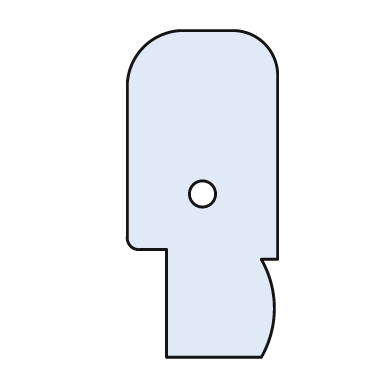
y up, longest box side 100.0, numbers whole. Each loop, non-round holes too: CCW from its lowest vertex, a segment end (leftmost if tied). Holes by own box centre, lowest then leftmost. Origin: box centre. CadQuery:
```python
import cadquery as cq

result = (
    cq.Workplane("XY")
    .moveTo(-11.0, -50.0)
    .lineTo(18.0, -50.0)
    .threePointArc((22.0, -35.0), (18.0, -20.0))
    .lineTo(23.0, -20.0)
    .lineTo(23.0, 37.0)
    .threePointArc((19.0, 46.0), (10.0, 50.0))
    .lineTo(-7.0, 50.0)
    .threePointArc((-18.0, 45.0), (-23.0, 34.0))
    .lineTo(-23.0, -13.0)
    .threePointArc((-22.0, -16.0), (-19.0, -17.0))
    .lineTo(-11.0, -17.0)
    .close()
    .moveTo(0.0, 0.0)
    .circle(4.0)
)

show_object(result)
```